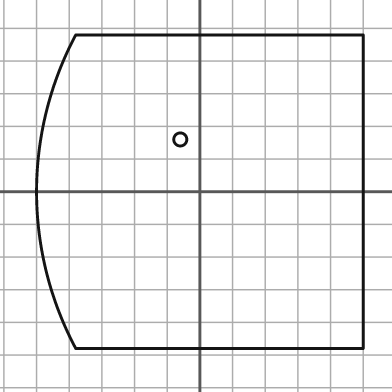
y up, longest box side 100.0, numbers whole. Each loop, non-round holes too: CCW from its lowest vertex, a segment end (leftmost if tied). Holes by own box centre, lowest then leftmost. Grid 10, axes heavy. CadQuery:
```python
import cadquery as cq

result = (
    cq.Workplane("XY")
    .moveTo(-38.0, -48.0)
    .lineTo(50.0, -48.0)
    .lineTo(50.0, 48.0)
    .lineTo(-38.0, 48.0)
    .threePointArc((-50.0, 0.0), (-38.0, -48.0))
    .close()
    .moveTo(-6.0, 16.0)
    .circle(2.0)
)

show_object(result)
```